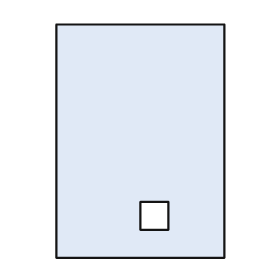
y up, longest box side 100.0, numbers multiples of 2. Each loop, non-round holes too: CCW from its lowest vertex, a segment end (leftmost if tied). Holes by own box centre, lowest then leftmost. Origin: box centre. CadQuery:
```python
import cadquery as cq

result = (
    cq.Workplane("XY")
    .moveTo(-36.0, -50.0)
    .lineTo(36.0, -50.0)
    .lineTo(36.0, 50.0)
    .lineTo(-36.0, 50.0)
    .close()
    .moveTo(0.0, -38.0)
    .lineTo(12.0, -38.0)
    .lineTo(12.0, -26.0)
    .lineTo(0.0, -26.0)
    .close()
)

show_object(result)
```